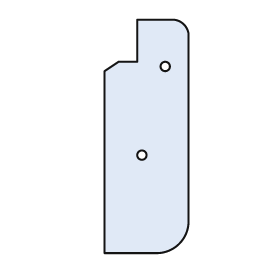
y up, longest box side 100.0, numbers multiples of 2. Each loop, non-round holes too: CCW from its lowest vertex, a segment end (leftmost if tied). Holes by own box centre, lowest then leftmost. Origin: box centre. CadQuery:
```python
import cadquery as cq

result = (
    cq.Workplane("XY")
    .moveTo(-18.0, -50.0)
    .lineTo(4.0, -50.0)
    .threePointArc((14.0, -46.0), (18.0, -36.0))
    .lineTo(18.0, 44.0)
    .threePointArc((16.0, 48.0), (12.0, 50.0))
    .lineTo(-4.0, 50.0)
    .lineTo(-4.0, 32.0)
    .lineTo(-12.0, 32.0)
    .lineTo(-18.0, 28.0)
    .close()
    .moveTo(-2.0, -8.0)
    .circle(2.0)
    .moveTo(8.0, 30.0)
    .circle(2.0)
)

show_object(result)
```